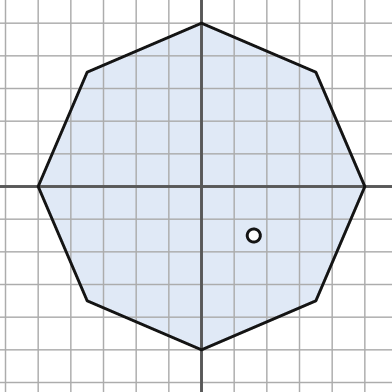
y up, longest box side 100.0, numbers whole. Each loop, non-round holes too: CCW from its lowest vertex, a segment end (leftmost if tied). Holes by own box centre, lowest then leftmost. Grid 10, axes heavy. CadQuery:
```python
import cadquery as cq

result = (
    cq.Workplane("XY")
    .moveTo(0.0, -50.0)
    .lineTo(35.0, -35.0)
    .lineTo(50.0, 0.0)
    .lineTo(35.0, 35.0)
    .lineTo(0.0, 50.0)
    .lineTo(-35.0, 35.0)
    .lineTo(-50.0, 0.0)
    .lineTo(-35.0, -35.0)
    .close()
    .moveTo(16.0, -15.0)
    .circle(2.0)
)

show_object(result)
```